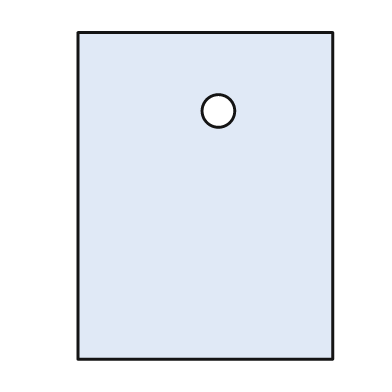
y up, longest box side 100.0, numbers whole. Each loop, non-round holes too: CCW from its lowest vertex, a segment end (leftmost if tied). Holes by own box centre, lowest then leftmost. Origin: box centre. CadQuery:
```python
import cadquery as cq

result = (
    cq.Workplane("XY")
    .moveTo(-39.0, -50.0)
    .lineTo(39.0, -50.0)
    .lineTo(39.0, 50.0)
    .lineTo(-39.0, 50.0)
    .close()
    .moveTo(4.0, 26.0)
    .circle(5.0)
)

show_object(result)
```